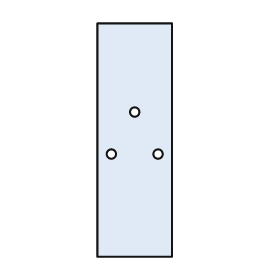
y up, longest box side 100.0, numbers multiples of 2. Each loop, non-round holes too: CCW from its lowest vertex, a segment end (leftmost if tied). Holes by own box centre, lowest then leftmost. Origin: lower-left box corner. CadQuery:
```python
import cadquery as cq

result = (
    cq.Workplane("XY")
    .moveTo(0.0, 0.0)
    .lineTo(32.0, 0.0)
    .lineTo(32.0, 100.0)
    .lineTo(0.0, 100.0)
    .close()
    .moveTo(6.0, 44.0)
    .circle(2.0)
    .moveTo(26.0, 44.0)
    .circle(2.0)
    .moveTo(16.0, 62.0)
    .circle(2.0)
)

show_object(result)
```